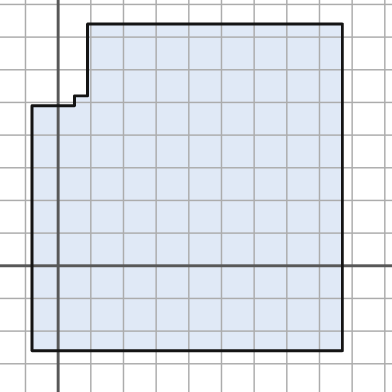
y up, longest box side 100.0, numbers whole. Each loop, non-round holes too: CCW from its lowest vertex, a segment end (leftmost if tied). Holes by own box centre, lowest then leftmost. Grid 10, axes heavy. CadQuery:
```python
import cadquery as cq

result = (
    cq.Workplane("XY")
    .moveTo(-8.0, -26.0)
    .lineTo(87.0, -26.0)
    .lineTo(87.0, 74.0)
    .lineTo(9.0, 74.0)
    .lineTo(9.0, 52.0)
    .lineTo(5.0, 52.0)
    .lineTo(5.0, 49.0)
    .lineTo(-8.0, 49.0)
    .close()
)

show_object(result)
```